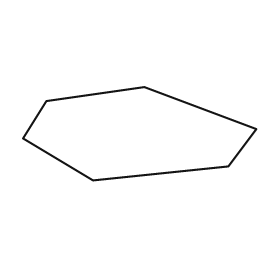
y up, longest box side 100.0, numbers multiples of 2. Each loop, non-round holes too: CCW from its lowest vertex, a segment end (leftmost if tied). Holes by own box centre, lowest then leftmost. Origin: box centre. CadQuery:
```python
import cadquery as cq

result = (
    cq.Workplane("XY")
    .moveTo(-20.0, -20.0)
    .lineTo(38.0, -14.0)
    .lineTo(50.0, 2.0)
    .lineTo(2.0, 20.0)
    .lineTo(-40.0, 14.0)
    .lineTo(-50.0, -2.0)
    .close()
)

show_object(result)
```